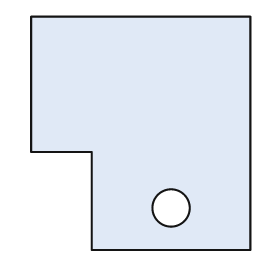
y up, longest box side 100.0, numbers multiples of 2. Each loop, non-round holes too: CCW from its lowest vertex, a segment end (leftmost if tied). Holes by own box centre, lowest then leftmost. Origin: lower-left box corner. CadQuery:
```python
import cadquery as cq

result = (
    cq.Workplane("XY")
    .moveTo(26.0, 0.0)
    .lineTo(94.0, 0.0)
    .lineTo(94.0, 100.0)
    .lineTo(0.0, 100.0)
    .lineTo(0.0, 42.0)
    .lineTo(26.0, 42.0)
    .close()
    .moveTo(60.0, 18.0)
    .circle(8.0)
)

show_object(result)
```